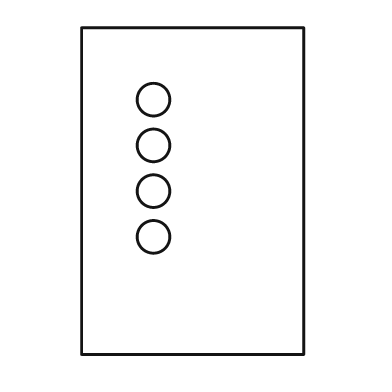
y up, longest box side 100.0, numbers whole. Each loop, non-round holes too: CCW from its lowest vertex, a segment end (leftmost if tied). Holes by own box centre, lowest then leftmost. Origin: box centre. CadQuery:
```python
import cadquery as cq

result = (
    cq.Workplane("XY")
    .moveTo(-34.0, -50.0)
    .lineTo(34.0, -50.0)
    .lineTo(34.0, 50.0)
    .lineTo(-34.0, 50.0)
    .close()
    .moveTo(-12.0, -14.0)
    .circle(5.0)
    .moveTo(-12.0, 0.0)
    .circle(5.0)
    .moveTo(-12.0, 14.0)
    .circle(5.0)
    .moveTo(-12.0, 28.0)
    .circle(5.0)
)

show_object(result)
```